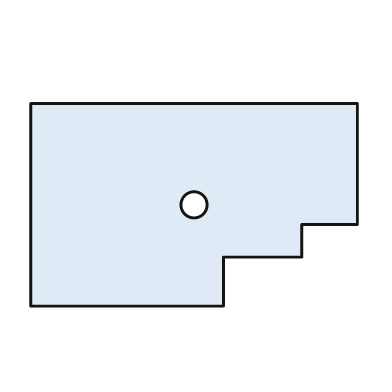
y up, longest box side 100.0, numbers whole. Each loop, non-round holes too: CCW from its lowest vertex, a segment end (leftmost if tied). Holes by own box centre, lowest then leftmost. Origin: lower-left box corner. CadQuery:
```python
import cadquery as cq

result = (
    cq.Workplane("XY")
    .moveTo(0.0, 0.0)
    .lineTo(59.0, 0.0)
    .lineTo(59.0, 15.0)
    .lineTo(83.0, 15.0)
    .lineTo(83.0, 25.0)
    .lineTo(100.0, 25.0)
    .lineTo(100.0, 62.0)
    .lineTo(0.0, 62.0)
    .close()
    .moveTo(50.0, 31.0)
    .circle(4.0)
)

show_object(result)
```